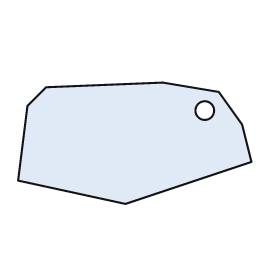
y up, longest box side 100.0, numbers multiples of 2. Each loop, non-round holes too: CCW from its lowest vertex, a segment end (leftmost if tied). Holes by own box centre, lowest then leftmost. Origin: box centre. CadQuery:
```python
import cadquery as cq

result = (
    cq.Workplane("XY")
    .moveTo(-4.0, -26.0)
    .lineTo(50.0, -8.0)
    .lineTo(46.0, 8.0)
    .lineTo(36.0, 22.0)
    .lineTo(12.0, 26.0)
    .lineTo(-38.0, 24.0)
    .lineTo(-46.0, 16.0)
    .lineTo(-50.0, -16.0)
    .close()
    .moveTo(30.0, 14.0)
    .circle(4.0)
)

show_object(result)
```